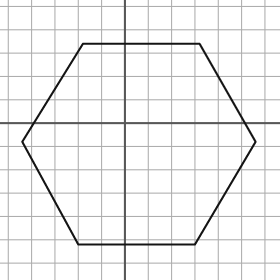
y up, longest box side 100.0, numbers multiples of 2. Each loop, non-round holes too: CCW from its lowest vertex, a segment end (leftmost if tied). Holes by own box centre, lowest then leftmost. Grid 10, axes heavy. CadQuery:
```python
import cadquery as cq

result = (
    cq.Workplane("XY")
    .moveTo(-20.0, -52.0)
    .lineTo(30.0, -52.0)
    .lineTo(56.0, -8.0)
    .lineTo(32.0, 34.0)
    .lineTo(-18.0, 34.0)
    .lineTo(-44.0, -8.0)
    .close()
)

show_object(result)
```